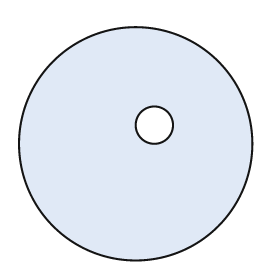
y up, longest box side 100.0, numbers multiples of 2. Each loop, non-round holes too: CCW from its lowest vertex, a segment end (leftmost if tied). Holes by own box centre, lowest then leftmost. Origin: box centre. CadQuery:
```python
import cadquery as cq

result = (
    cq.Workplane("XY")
    .moveTo(0.0, 0.0)
    .circle(50.0)
    .moveTo(8.0, 8.0)
    .circle(8.0)
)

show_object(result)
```